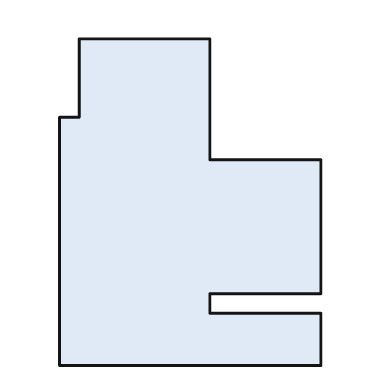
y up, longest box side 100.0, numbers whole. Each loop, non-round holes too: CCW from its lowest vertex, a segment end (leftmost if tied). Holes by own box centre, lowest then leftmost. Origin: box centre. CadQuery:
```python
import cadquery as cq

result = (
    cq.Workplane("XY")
    .moveTo(-40.0, -50.0)
    .lineTo(40.0, -50.0)
    .lineTo(40.0, -34.0)
    .lineTo(6.0, -34.0)
    .lineTo(6.0, -28.0)
    .lineTo(40.0, -28.0)
    .lineTo(40.0, 13.0)
    .lineTo(6.0, 13.0)
    .lineTo(6.0, 50.0)
    .lineTo(-34.0, 50.0)
    .lineTo(-34.0, 26.0)
    .lineTo(-40.0, 26.0)
    .close()
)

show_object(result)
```